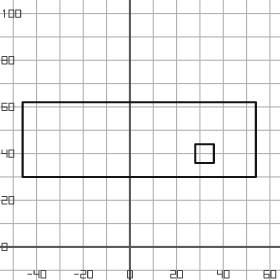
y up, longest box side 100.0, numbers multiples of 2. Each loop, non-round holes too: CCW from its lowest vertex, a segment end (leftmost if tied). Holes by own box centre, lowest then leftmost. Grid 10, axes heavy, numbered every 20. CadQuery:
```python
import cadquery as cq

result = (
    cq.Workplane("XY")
    .moveTo(-46.0, 30.0)
    .lineTo(54.0, 30.0)
    .lineTo(54.0, 62.0)
    .lineTo(-46.0, 62.0)
    .close()
    .moveTo(28.0, 36.0)
    .lineTo(36.0, 36.0)
    .lineTo(36.0, 44.0)
    .lineTo(28.0, 44.0)
    .close()
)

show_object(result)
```